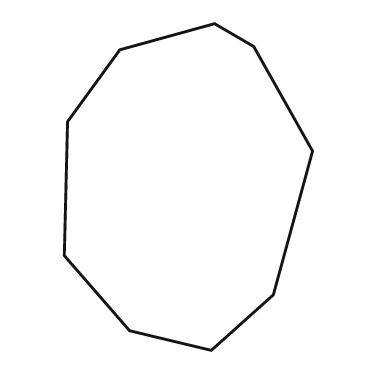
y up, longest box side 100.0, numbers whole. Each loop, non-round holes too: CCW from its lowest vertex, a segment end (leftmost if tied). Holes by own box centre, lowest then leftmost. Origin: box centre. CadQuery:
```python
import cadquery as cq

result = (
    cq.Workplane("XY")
    .moveTo(7.0, -50.0)
    .lineTo(26.0, -33.0)
    .lineTo(38.0, 11.0)
    .lineTo(20.0, 43.0)
    .lineTo(8.0, 50.0)
    .lineTo(-21.0, 42.0)
    .lineTo(-37.0, 20.0)
    .lineTo(-38.0, -21.0)
    .lineTo(-18.0, -44.0)
    .close()
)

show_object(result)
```